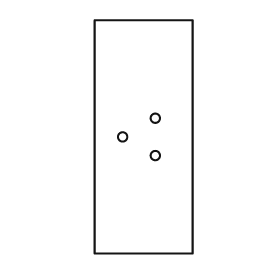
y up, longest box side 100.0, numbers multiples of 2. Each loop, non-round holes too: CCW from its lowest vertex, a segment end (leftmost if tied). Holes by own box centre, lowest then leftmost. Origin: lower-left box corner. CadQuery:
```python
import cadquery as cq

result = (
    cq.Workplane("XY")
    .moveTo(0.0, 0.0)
    .lineTo(42.0, 0.0)
    .lineTo(42.0, 100.0)
    .lineTo(0.0, 100.0)
    .close()
    .moveTo(26.0, 42.0)
    .circle(2.0)
    .moveTo(12.0, 50.0)
    .circle(2.0)
    .moveTo(26.0, 58.0)
    .circle(2.0)
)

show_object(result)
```